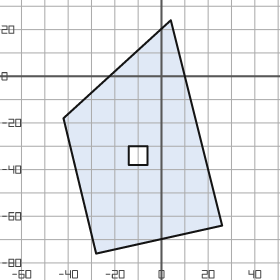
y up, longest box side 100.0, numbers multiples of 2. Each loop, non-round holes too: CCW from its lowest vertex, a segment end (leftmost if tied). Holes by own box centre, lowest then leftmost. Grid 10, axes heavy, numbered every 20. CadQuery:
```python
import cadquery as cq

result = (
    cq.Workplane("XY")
    .moveTo(-28.0, -76.0)
    .lineTo(26.0, -64.0)
    .lineTo(4.0, 24.0)
    .lineTo(-42.0, -18.0)
    .close()
    .moveTo(-14.0, -38.0)
    .lineTo(-6.0, -38.0)
    .lineTo(-6.0, -30.0)
    .lineTo(-14.0, -30.0)
    .close()
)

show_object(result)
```